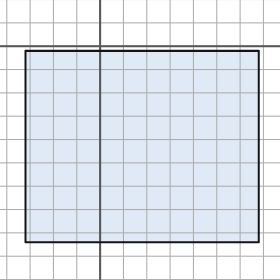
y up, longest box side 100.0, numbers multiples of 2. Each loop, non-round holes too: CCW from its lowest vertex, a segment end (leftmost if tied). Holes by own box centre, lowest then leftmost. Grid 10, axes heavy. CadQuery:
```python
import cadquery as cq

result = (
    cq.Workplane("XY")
    .moveTo(-32.0, -84.0)
    .lineTo(68.0, -84.0)
    .lineTo(68.0, -2.0)
    .lineTo(-32.0, -2.0)
    .close()
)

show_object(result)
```